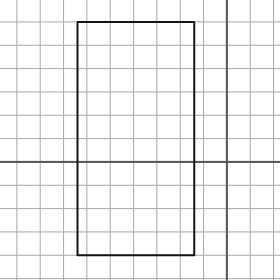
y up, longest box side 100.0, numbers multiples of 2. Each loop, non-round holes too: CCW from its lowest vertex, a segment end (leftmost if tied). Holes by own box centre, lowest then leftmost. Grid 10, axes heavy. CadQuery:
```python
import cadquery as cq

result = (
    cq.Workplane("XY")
    .moveTo(-64.0, -40.0)
    .lineTo(-14.0, -40.0)
    .lineTo(-14.0, 60.0)
    .lineTo(-64.0, 60.0)
    .close()
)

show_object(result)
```